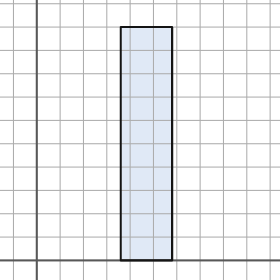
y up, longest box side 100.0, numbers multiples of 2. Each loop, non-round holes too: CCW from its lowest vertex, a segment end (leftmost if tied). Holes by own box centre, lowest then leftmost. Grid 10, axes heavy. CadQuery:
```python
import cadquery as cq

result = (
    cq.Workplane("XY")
    .moveTo(36.0, 0.0)
    .lineTo(58.0, 0.0)
    .lineTo(58.0, 100.0)
    .lineTo(36.0, 100.0)
    .close()
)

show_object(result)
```